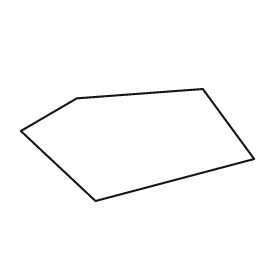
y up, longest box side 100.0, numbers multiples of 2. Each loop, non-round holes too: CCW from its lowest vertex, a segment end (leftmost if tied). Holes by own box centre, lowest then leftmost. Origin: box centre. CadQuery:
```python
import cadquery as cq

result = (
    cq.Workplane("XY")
    .moveTo(-18.0, -24.0)
    .lineTo(50.0, -6.0)
    .lineTo(28.0, 24.0)
    .lineTo(-26.0, 20.0)
    .lineTo(-50.0, 6.0)
    .close()
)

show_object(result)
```